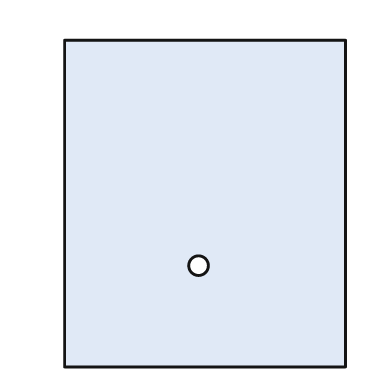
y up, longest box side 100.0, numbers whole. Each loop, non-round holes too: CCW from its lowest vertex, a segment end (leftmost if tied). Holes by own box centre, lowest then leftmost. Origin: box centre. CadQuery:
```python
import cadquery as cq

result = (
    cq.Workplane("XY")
    .moveTo(-43.0, -50.0)
    .lineTo(43.0, -50.0)
    .lineTo(43.0, 50.0)
    .lineTo(-43.0, 50.0)
    .close()
    .moveTo(-2.0, -19.0)
    .circle(3.0)
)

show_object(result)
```